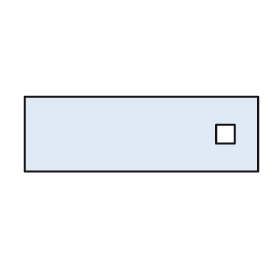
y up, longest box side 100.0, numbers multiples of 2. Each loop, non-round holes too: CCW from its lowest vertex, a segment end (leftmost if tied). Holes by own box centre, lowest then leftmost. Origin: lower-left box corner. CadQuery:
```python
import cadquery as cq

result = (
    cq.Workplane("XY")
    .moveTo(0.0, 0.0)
    .lineTo(100.0, 0.0)
    .lineTo(100.0, 32.0)
    .lineTo(0.0, 32.0)
    .close()
    .moveTo(82.0, 12.0)
    .lineTo(90.0, 12.0)
    .lineTo(90.0, 20.0)
    .lineTo(82.0, 20.0)
    .close()
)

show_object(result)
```